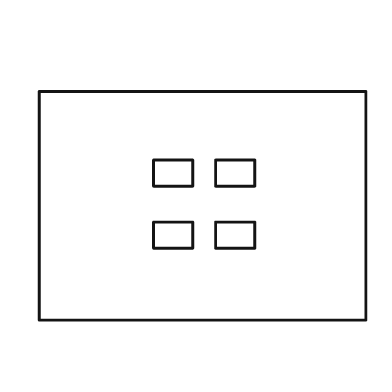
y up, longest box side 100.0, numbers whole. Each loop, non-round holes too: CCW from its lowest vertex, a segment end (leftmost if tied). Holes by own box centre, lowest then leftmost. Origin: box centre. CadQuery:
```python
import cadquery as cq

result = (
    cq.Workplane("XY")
    .moveTo(-50.0, -35.0)
    .lineTo(50.0, -35.0)
    .lineTo(50.0, 35.0)
    .lineTo(-50.0, 35.0)
    .close()
    .moveTo(-15.0, -13.0)
    .lineTo(-3.0, -13.0)
    .lineTo(-3.0, -5.0)
    .lineTo(-15.0, -5.0)
    .close()
    .moveTo(4.0, -13.0)
    .lineTo(16.0, -13.0)
    .lineTo(16.0, -5.0)
    .lineTo(4.0, -5.0)
    .close()
    .moveTo(-15.0, 6.0)
    .lineTo(-3.0, 6.0)
    .lineTo(-3.0, 14.0)
    .lineTo(-15.0, 14.0)
    .close()
    .moveTo(4.0, 6.0)
    .lineTo(16.0, 6.0)
    .lineTo(16.0, 14.0)
    .lineTo(4.0, 14.0)
    .close()
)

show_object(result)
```